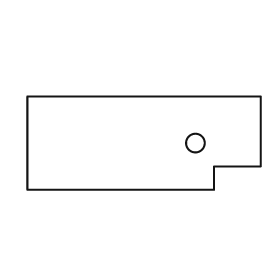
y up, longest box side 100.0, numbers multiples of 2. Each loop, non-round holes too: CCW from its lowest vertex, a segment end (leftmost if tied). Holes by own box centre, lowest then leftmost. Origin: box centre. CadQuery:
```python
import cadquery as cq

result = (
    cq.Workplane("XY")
    .moveTo(-50.0, -20.0)
    .lineTo(30.0, -20.0)
    .lineTo(30.0, -10.0)
    .lineTo(50.0, -10.0)
    .lineTo(50.0, 20.0)
    .lineTo(-50.0, 20.0)
    .close()
    .moveTo(22.0, 0.0)
    .circle(4.0)
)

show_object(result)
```